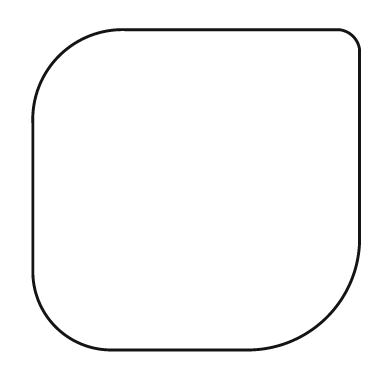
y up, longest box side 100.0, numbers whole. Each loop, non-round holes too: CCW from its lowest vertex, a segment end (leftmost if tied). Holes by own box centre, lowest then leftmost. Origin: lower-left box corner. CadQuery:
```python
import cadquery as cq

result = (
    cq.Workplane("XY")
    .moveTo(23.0, 0.0)
    .lineTo(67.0, 0.0)
    .threePointArc((90.0, 10.0), (100.0, 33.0))
    .lineTo(100.0, 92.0)
    .threePointArc((98.0, 96.0), (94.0, 98.0))
    .lineTo(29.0, 98.0)
    .threePointArc((8.0, 90.0), (0.0, 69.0))
    .lineTo(0.0, 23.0)
    .threePointArc((7.0, 7.0), (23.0, 0.0))
    .close()
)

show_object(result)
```